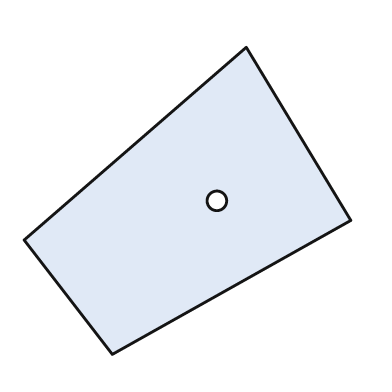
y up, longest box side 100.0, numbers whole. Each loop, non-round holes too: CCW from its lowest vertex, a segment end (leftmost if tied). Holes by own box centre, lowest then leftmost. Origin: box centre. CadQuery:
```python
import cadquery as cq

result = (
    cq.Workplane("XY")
    .moveTo(-23.0, -47.0)
    .lineTo(50.0, -6.0)
    .lineTo(18.0, 47.0)
    .lineTo(-50.0, -12.0)
    .close()
    .moveTo(9.0, 0.0)
    .circle(3.0)
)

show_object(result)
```